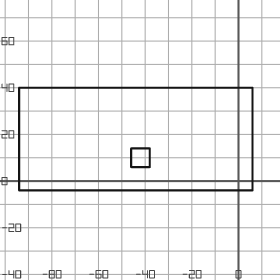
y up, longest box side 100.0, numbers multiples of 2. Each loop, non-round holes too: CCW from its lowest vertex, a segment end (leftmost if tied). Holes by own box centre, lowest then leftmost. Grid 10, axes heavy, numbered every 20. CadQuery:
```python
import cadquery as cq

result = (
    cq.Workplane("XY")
    .moveTo(-94.0, -4.0)
    .lineTo(6.0, -4.0)
    .lineTo(6.0, 40.0)
    .lineTo(-94.0, 40.0)
    .close()
    .moveTo(-46.0, 6.0)
    .lineTo(-38.0, 6.0)
    .lineTo(-38.0, 14.0)
    .lineTo(-46.0, 14.0)
    .close()
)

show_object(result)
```